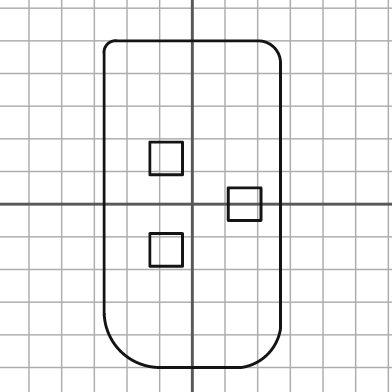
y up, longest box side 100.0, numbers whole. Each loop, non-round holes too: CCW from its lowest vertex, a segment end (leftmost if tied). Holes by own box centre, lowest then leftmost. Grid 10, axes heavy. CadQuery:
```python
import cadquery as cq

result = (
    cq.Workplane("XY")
    .moveTo(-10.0, -50.0)
    .lineTo(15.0, -50.0)
    .threePointArc((23.0, -46.0), (27.0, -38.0))
    .lineTo(27.0, 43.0)
    .threePointArc((25.0, 48.0), (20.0, 50.0))
    .lineTo(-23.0, 50.0)
    .threePointArc((-26.0, 49.0), (-27.0, 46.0))
    .lineTo(-27.0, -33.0)
    .threePointArc((-22.0, -45.0), (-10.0, -50.0))
    .close()
    .moveTo(-13.0, -19.0)
    .lineTo(-3.0, -19.0)
    .lineTo(-3.0, -9.0)
    .lineTo(-13.0, -9.0)
    .close()
    .moveTo(11.0, -5.0)
    .lineTo(21.0, -5.0)
    .lineTo(21.0, 5.0)
    .lineTo(11.0, 5.0)
    .close()
    .moveTo(-13.0, 9.0)
    .lineTo(-3.0, 9.0)
    .lineTo(-3.0, 19.0)
    .lineTo(-13.0, 19.0)
    .close()
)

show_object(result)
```